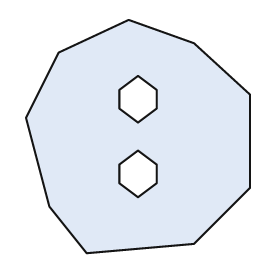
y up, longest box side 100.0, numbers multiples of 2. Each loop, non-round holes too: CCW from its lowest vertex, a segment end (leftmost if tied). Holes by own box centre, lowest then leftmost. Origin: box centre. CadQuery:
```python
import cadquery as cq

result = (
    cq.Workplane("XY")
    .moveTo(-22.0, -50.0)
    .lineTo(24.0, -46.0)
    .lineTo(48.0, -22.0)
    .lineTo(48.0, 18.0)
    .lineTo(24.0, 40.0)
    .lineTo(-4.0, 50.0)
    .lineTo(-34.0, 36.0)
    .lineTo(-48.0, 8.0)
    .lineTo(-38.0, -30.0)
    .close()
    .moveTo(0.0, -26.0)
    .lineTo(8.0, -20.0)
    .lineTo(8.0, -12.0)
    .lineTo(0.0, -6.0)
    .lineTo(-8.0, -12.0)
    .lineTo(-8.0, -20.0)
    .close()
    .moveTo(0.0, 6.0)
    .lineTo(8.0, 12.0)
    .lineTo(8.0, 20.0)
    .lineTo(0.0, 26.0)
    .lineTo(-8.0, 20.0)
    .lineTo(-8.0, 12.0)
    .close()
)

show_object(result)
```